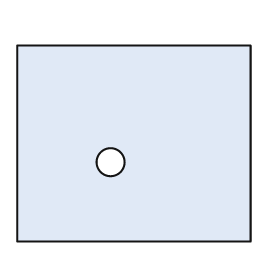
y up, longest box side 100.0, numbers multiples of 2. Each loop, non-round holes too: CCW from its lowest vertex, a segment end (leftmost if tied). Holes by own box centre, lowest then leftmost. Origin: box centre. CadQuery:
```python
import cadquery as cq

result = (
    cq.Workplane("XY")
    .moveTo(-50.0, -42.0)
    .lineTo(50.0, -42.0)
    .lineTo(50.0, 42.0)
    .lineTo(-50.0, 42.0)
    .close()
    .moveTo(-10.0, -8.0)
    .circle(6.0)
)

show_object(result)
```